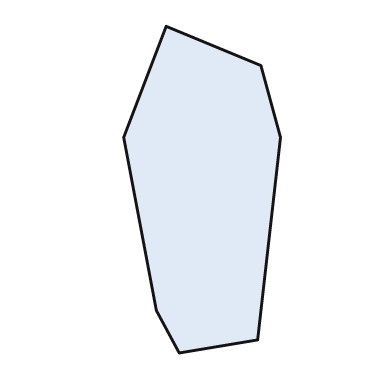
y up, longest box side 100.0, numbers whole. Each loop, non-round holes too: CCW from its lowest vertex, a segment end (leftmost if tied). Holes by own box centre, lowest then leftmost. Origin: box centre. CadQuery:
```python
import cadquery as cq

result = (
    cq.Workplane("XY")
    .moveTo(-7.0, -50.0)
    .lineTo(17.0, -46.0)
    .lineTo(24.0, 16.0)
    .lineTo(18.0, 38.0)
    .lineTo(-11.0, 50.0)
    .lineTo(-24.0, 16.0)
    .lineTo(-14.0, -37.0)
    .close()
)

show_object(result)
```